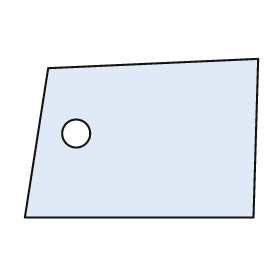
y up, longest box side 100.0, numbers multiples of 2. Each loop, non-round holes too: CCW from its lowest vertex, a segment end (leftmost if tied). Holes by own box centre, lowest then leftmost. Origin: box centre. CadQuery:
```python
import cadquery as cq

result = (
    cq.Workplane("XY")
    .moveTo(-50.0, -34.0)
    .lineTo(48.0, -34.0)
    .lineTo(50.0, 34.0)
    .lineTo(-40.0, 30.0)
    .close()
    .moveTo(-28.0, 2.0)
    .circle(6.0)
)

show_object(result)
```